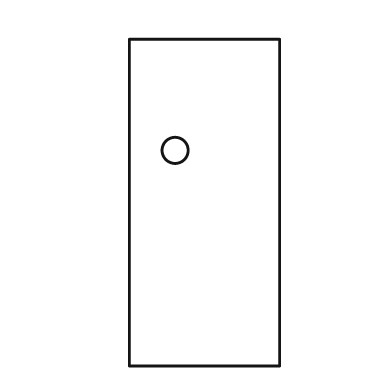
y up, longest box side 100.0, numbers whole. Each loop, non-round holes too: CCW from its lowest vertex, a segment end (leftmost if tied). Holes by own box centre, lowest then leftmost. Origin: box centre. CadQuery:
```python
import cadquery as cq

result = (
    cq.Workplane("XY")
    .moveTo(-23.0, -50.0)
    .lineTo(23.0, -50.0)
    .lineTo(23.0, 50.0)
    .lineTo(-23.0, 50.0)
    .close()
    .moveTo(-9.0, 16.0)
    .circle(4.0)
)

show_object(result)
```